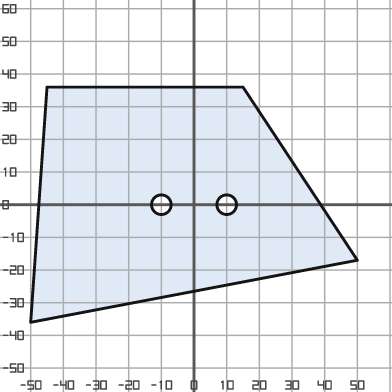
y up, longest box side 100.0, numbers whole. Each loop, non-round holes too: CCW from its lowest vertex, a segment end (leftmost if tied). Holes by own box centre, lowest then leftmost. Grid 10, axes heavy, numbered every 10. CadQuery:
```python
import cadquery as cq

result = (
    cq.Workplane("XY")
    .moveTo(-50.0, -36.0)
    .lineTo(50.0, -17.0)
    .lineTo(15.0, 36.0)
    .lineTo(-45.0, 36.0)
    .close()
    .moveTo(-10.0, 0.0)
    .circle(3.0)
    .moveTo(10.0, 0.0)
    .circle(3.0)
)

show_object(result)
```